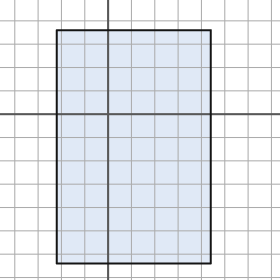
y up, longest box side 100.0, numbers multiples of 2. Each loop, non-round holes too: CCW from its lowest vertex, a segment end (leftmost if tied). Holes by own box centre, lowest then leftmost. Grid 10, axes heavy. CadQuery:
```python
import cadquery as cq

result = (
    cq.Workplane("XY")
    .moveTo(-22.0, -64.0)
    .lineTo(44.0, -64.0)
    .lineTo(44.0, 36.0)
    .lineTo(-22.0, 36.0)
    .close()
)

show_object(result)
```